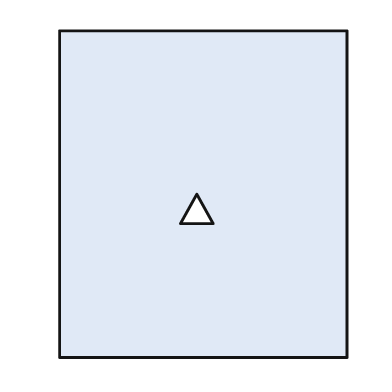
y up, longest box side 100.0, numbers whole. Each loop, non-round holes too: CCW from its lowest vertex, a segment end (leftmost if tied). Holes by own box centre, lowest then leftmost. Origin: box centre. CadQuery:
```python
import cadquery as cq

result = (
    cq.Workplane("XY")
    .moveTo(-44.0, -50.0)
    .lineTo(44.0, -50.0)
    .lineTo(44.0, 50.0)
    .lineTo(-44.0, 50.0)
    .close()
    .moveTo(-7.0, -9.0)
    .lineTo(3.0, -9.0)
    .lineTo(-2.0, 0.0)
    .close()
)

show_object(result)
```